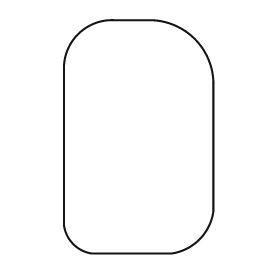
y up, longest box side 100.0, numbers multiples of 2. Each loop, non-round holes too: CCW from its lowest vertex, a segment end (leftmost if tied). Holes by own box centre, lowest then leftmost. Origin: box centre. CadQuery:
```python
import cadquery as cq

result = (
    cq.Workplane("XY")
    .moveTo(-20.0, -50.0)
    .lineTo(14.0, -50.0)
    .threePointArc((26.0, -44.0), (32.0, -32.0))
    .lineTo(32.0, 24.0)
    .threePointArc((24.0, 42.0), (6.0, 50.0))
    .lineTo(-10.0, 50.0)
    .threePointArc((-26.0, 44.0), (-32.0, 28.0))
    .lineTo(-32.0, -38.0)
    .threePointArc((-28.0, -46.0), (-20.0, -50.0))
    .close()
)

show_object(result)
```